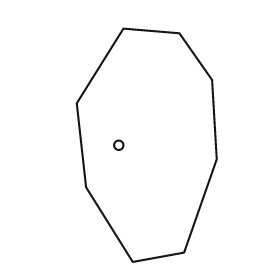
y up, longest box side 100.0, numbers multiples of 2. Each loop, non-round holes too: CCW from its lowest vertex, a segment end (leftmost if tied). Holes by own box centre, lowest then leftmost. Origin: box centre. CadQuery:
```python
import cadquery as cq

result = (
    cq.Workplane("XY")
    .moveTo(-6.0, -50.0)
    .lineTo(16.0, -46.0)
    .lineTo(30.0, -6.0)
    .lineTo(28.0, 28.0)
    .lineTo(14.0, 48.0)
    .lineTo(-10.0, 50.0)
    .lineTo(-30.0, 18.0)
    .lineTo(-26.0, -18.0)
    .close()
    .moveTo(-12.0, 0.0)
    .circle(2.0)
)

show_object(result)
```